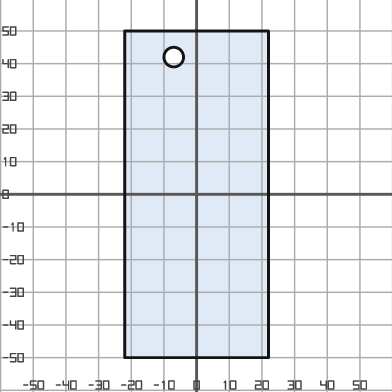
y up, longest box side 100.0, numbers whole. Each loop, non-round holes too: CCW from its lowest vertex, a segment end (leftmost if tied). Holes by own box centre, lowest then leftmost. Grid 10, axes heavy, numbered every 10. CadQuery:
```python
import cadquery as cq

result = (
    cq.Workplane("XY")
    .moveTo(-22.0, -50.0)
    .lineTo(22.0, -50.0)
    .lineTo(22.0, 50.0)
    .lineTo(-22.0, 50.0)
    .close()
    .moveTo(-7.0, 42.0)
    .circle(3.0)
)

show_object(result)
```